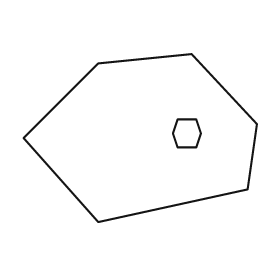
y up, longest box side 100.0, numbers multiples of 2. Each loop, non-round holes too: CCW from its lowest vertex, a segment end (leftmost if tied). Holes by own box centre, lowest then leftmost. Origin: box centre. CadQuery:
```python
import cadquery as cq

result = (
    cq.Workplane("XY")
    .moveTo(-18.0, -36.0)
    .lineTo(46.0, -22.0)
    .lineTo(50.0, 6.0)
    .lineTo(22.0, 36.0)
    .lineTo(-18.0, 32.0)
    .lineTo(-50.0, 0.0)
    .close()
    .moveTo(16.0, -4.0)
    .lineTo(24.0, -4.0)
    .lineTo(26.0, 2.0)
    .lineTo(24.0, 8.0)
    .lineTo(16.0, 8.0)
    .lineTo(14.0, 2.0)
    .close()
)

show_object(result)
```